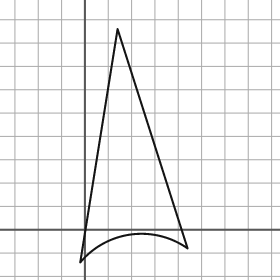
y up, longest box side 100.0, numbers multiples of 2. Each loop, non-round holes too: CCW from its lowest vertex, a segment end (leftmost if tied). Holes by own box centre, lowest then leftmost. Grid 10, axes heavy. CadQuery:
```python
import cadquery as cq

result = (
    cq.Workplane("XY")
    .moveTo(-2.0, -14.0)
    .threePointArc((20.0, -2.0), (44.0, -8.0))
    .lineTo(14.0, 86.0)
    .close()
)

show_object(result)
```